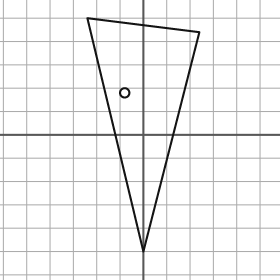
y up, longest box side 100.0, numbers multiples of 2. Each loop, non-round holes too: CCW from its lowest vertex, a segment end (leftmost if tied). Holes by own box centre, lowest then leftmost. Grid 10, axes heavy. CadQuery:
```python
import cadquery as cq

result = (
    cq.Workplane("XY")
    .moveTo(0.0, -50.0)
    .lineTo(24.0, 44.0)
    .lineTo(-24.0, 50.0)
    .close()
    .moveTo(-8.0, 18.0)
    .circle(2.0)
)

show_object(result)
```